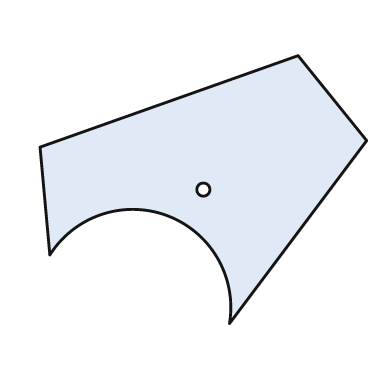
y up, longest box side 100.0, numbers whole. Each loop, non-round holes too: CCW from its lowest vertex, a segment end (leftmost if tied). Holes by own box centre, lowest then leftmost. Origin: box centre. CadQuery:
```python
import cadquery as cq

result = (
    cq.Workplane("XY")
    .moveTo(8.0, -41.0)
    .lineTo(50.0, 15.0)
    .lineTo(29.0, 41.0)
    .lineTo(-50.0, 13.0)
    .lineTo(-47.0, -20.0)
    .threePointArc((-11.0, -8.0), (8.0, -41.0))
    .close()
    .moveTo(0.0, 0.0)
    .circle(2.0)
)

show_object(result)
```